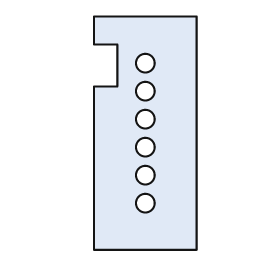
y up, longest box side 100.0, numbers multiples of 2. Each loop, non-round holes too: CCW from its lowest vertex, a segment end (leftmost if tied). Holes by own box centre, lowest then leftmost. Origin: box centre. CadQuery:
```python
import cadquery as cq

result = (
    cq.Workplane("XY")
    .moveTo(-22.0, -50.0)
    .lineTo(22.0, -50.0)
    .lineTo(22.0, 50.0)
    .lineTo(-22.0, 50.0)
    .lineTo(-22.0, 38.0)
    .lineTo(-12.0, 38.0)
    .lineTo(-12.0, 20.0)
    .lineTo(-22.0, 20.0)
    .close()
    .moveTo(0.0, -30.0)
    .circle(4.0)
    .moveTo(0.0, -18.0)
    .circle(4.0)
    .moveTo(0.0, -6.0)
    .circle(4.0)
    .moveTo(0.0, 6.0)
    .circle(4.0)
    .moveTo(0.0, 18.0)
    .circle(4.0)
    .moveTo(0.0, 30.0)
    .circle(4.0)
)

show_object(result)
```